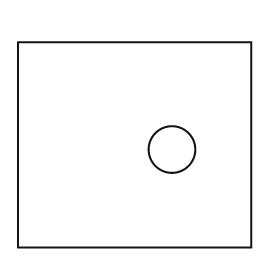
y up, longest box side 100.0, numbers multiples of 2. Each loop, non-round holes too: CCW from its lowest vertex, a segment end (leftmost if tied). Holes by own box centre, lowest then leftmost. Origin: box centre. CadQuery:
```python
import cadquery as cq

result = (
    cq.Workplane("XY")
    .moveTo(-50.0, -44.0)
    .lineTo(50.0, -44.0)
    .lineTo(50.0, 44.0)
    .lineTo(-50.0, 44.0)
    .close()
    .moveTo(16.0, -2.0)
    .circle(10.0)
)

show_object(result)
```